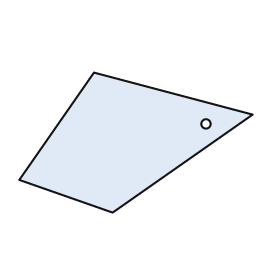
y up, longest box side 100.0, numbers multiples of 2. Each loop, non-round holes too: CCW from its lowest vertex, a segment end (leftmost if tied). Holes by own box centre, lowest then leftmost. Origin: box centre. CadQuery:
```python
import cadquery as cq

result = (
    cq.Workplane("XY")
    .moveTo(-10.0, -30.0)
    .lineTo(50.0, 12.0)
    .lineTo(-18.0, 30.0)
    .lineTo(-50.0, -16.0)
    .close()
    .moveTo(30.0, 8.0)
    .circle(2.0)
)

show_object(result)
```